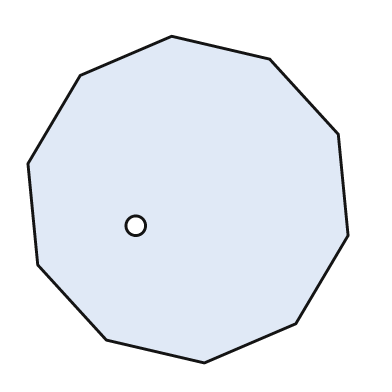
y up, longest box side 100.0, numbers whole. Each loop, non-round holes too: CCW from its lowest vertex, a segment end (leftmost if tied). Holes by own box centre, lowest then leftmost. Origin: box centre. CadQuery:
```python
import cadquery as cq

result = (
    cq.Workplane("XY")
    .moveTo(5.0, -50.0)
    .lineTo(33.0, -38.0)
    .lineTo(49.0, -11.0)
    .lineTo(46.0, 20.0)
    .lineTo(25.0, 43.0)
    .lineTo(-5.0, 50.0)
    .lineTo(-33.0, 38.0)
    .lineTo(-49.0, 11.0)
    .lineTo(-46.0, -20.0)
    .lineTo(-25.0, -43.0)
    .close()
    .moveTo(-16.0, -8.0)
    .circle(3.0)
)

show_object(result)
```